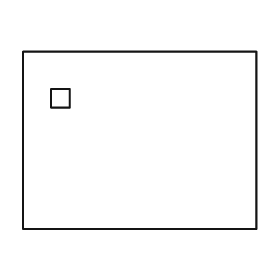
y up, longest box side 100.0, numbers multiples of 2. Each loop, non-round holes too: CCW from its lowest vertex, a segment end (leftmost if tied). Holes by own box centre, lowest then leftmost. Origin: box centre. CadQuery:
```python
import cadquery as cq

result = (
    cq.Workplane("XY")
    .moveTo(-50.0, -38.0)
    .lineTo(50.0, -38.0)
    .lineTo(50.0, 38.0)
    .lineTo(-50.0, 38.0)
    .close()
    .moveTo(-38.0, 14.0)
    .lineTo(-30.0, 14.0)
    .lineTo(-30.0, 22.0)
    .lineTo(-38.0, 22.0)
    .close()
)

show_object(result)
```